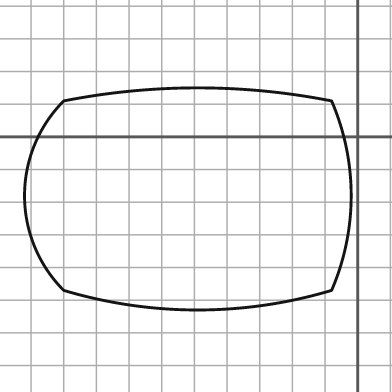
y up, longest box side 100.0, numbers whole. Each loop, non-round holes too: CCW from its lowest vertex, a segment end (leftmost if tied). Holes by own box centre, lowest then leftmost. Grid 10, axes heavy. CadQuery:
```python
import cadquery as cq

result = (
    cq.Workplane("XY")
    .moveTo(-90.0, -47.0)
    .threePointArc((-49.0, -53.0), (-8.0, -47.0))
    .threePointArc((-2.0, -18.0), (-8.0, 11.0))
    .threePointArc((-49.0, 15.0), (-90.0, 11.0))
    .threePointArc((-102.0, -18.0), (-90.0, -47.0))
    .close()
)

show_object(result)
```